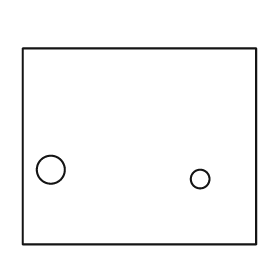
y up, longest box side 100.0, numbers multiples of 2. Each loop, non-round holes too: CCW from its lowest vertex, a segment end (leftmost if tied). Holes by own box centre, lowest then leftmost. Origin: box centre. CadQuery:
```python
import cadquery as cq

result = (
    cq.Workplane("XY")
    .moveTo(-50.0, -42.0)
    .lineTo(50.0, -42.0)
    .lineTo(50.0, 42.0)
    .lineTo(-50.0, 42.0)
    .close()
    .moveTo(26.0, -14.0)
    .circle(4.0)
    .moveTo(-38.0, -10.0)
    .circle(6.0)
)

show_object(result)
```